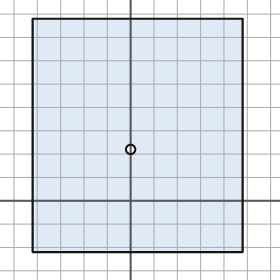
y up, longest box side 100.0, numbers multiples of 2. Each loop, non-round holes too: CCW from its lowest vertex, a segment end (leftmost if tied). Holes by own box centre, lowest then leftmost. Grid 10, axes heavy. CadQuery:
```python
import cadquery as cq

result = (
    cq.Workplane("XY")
    .moveTo(-42.0, -22.0)
    .lineTo(48.0, -22.0)
    .lineTo(48.0, 78.0)
    .lineTo(-42.0, 78.0)
    .close()
    .moveTo(0.0, 22.0)
    .circle(2.0)
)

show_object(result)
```